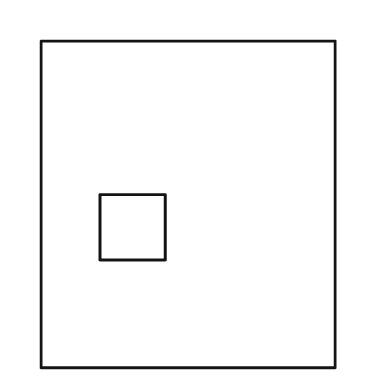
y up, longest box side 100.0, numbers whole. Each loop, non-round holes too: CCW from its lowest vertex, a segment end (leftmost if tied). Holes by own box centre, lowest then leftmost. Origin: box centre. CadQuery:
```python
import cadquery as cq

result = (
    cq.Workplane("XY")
    .moveTo(-45.0, -50.0)
    .lineTo(45.0, -50.0)
    .lineTo(45.0, 50.0)
    .lineTo(-45.0, 50.0)
    .close()
    .moveTo(-27.0, -17.0)
    .lineTo(-7.0, -17.0)
    .lineTo(-7.0, 3.0)
    .lineTo(-27.0, 3.0)
    .close()
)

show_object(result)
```